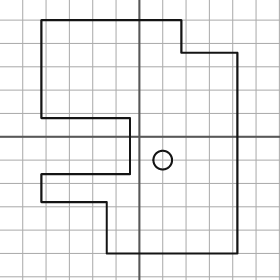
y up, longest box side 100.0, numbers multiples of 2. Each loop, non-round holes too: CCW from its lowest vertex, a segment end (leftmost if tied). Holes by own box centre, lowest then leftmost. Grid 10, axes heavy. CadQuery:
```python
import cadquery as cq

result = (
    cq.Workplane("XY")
    .moveTo(-14.0, -50.0)
    .lineTo(42.0, -50.0)
    .lineTo(42.0, 36.0)
    .lineTo(18.0, 36.0)
    .lineTo(18.0, 50.0)
    .lineTo(-42.0, 50.0)
    .lineTo(-42.0, 8.0)
    .lineTo(-4.0, 8.0)
    .lineTo(-4.0, -16.0)
    .lineTo(-42.0, -16.0)
    .lineTo(-42.0, -28.0)
    .lineTo(-14.0, -28.0)
    .close()
    .moveTo(10.0, -10.0)
    .circle(4.0)
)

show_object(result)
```